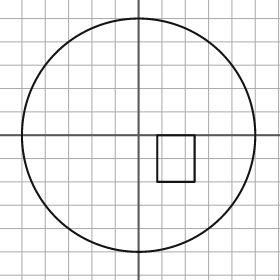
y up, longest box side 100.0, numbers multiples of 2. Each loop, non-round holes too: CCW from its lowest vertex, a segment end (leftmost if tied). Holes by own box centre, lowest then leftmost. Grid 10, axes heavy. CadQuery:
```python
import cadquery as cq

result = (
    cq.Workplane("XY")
    .moveTo(0.0, 0.0)
    .circle(50.0)
    .moveTo(8.0, -20.0)
    .lineTo(24.0, -20.0)
    .lineTo(24.0, 0.0)
    .lineTo(8.0, 0.0)
    .close()
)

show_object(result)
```